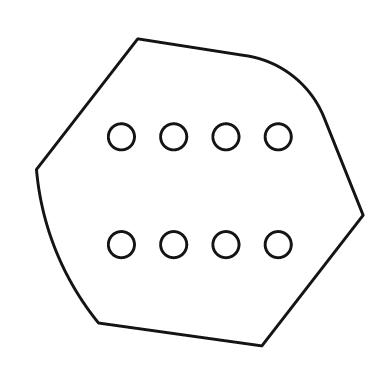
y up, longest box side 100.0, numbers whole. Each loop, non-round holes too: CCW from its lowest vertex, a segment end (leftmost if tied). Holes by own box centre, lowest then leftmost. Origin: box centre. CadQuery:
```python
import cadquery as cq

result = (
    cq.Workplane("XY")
    .moveTo(19.0, -47.0)
    .lineTo(50.0, -7.0)
    .lineTo(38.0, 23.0)
    .threePointArc((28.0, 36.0), (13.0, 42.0))
    .lineTo(-19.0, 47.0)
    .lineTo(-50.0, 7.0)
    .threePointArc((-44.0, -18.0), (-31.0, -40.0))
    .close()
    .moveTo(-24.0, -16.0)
    .circle(4.0)
    .moveTo(-8.0, -16.0)
    .circle(4.0)
    .moveTo(8.0, -16.0)
    .circle(4.0)
    .moveTo(24.0, -16.0)
    .circle(4.0)
    .moveTo(-24.0, 17.0)
    .circle(4.0)
    .moveTo(-8.0, 17.0)
    .circle(4.0)
    .moveTo(8.0, 17.0)
    .circle(4.0)
    .moveTo(24.0, 17.0)
    .circle(4.0)
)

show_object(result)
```